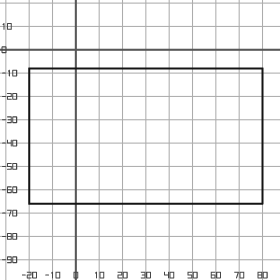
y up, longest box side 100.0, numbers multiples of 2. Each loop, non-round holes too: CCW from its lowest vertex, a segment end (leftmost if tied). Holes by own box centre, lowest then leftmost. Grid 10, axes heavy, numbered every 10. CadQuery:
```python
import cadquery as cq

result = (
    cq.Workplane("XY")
    .moveTo(-20.0, -66.0)
    .lineTo(80.0, -66.0)
    .lineTo(80.0, -8.0)
    .lineTo(-20.0, -8.0)
    .close()
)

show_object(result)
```